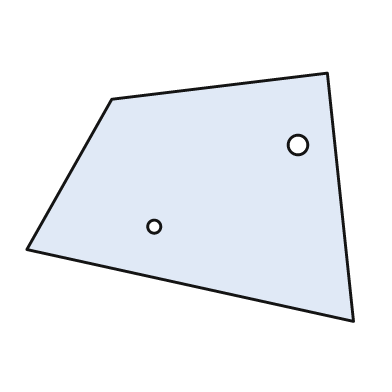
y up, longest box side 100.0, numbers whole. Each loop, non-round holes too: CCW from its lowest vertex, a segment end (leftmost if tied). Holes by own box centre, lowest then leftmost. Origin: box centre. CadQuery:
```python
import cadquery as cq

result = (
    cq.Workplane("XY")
    .moveTo(50.0, -38.0)
    .lineTo(42.0, 38.0)
    .lineTo(-24.0, 30.0)
    .lineTo(-50.0, -16.0)
    .close()
    .moveTo(-11.0, -9.0)
    .circle(2.0)
    .moveTo(33.0, 16.0)
    .circle(3.0)
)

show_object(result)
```